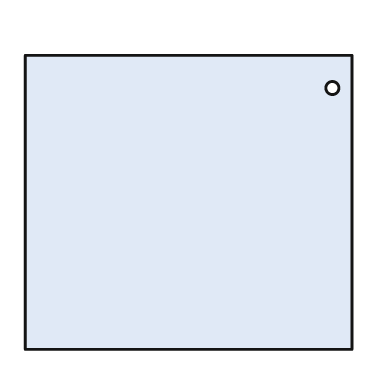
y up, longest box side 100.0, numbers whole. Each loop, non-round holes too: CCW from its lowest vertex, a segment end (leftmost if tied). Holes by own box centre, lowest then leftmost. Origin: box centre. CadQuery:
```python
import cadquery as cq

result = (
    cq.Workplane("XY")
    .moveTo(-50.0, -45.0)
    .lineTo(50.0, -45.0)
    .lineTo(50.0, 45.0)
    .lineTo(-50.0, 45.0)
    .close()
    .moveTo(44.0, 35.0)
    .circle(2.0)
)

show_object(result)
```